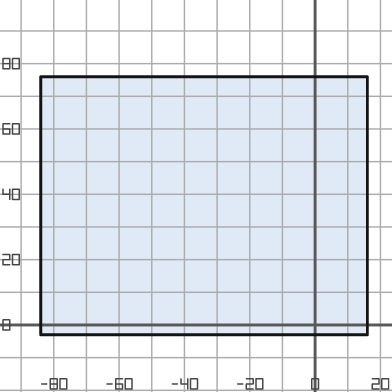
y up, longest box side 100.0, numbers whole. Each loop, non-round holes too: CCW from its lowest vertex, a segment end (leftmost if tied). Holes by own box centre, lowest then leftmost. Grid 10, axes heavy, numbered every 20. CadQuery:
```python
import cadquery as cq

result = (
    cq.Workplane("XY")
    .moveTo(-84.0, -3.0)
    .lineTo(16.0, -3.0)
    .lineTo(16.0, 76.0)
    .lineTo(-84.0, 76.0)
    .close()
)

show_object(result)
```